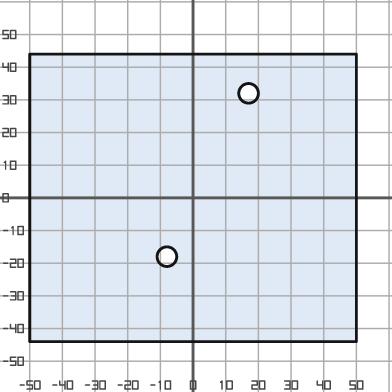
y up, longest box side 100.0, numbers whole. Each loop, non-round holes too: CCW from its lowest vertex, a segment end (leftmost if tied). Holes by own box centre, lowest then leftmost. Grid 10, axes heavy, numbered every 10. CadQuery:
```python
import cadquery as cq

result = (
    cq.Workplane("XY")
    .moveTo(-50.0, -44.0)
    .lineTo(50.0, -44.0)
    .lineTo(50.0, 44.0)
    .lineTo(-50.0, 44.0)
    .close()
    .moveTo(-8.0, -18.0)
    .circle(3.0)
    .moveTo(17.0, 32.0)
    .circle(3.0)
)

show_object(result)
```